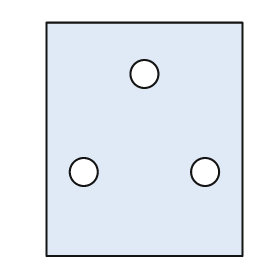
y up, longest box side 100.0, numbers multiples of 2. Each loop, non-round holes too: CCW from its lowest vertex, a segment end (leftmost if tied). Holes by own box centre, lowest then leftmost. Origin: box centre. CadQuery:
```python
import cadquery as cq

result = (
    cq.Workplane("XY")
    .moveTo(-42.0, -50.0)
    .lineTo(42.0, -50.0)
    .lineTo(42.0, 50.0)
    .lineTo(-42.0, 50.0)
    .close()
    .moveTo(-26.0, -14.0)
    .circle(6.0)
    .moveTo(26.0, -14.0)
    .circle(6.0)
    .moveTo(0.0, 28.0)
    .circle(6.0)
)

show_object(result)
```